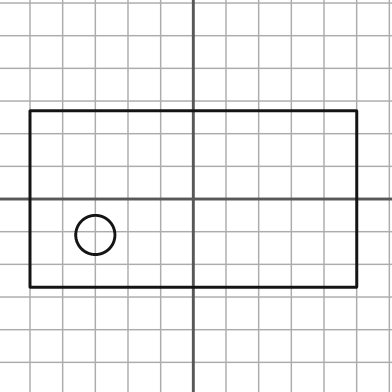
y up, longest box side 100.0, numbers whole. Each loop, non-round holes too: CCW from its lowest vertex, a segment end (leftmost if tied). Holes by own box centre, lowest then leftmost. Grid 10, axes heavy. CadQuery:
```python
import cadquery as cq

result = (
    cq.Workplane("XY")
    .moveTo(-50.0, -27.0)
    .lineTo(50.0, -27.0)
    .lineTo(50.0, 27.0)
    .lineTo(-50.0, 27.0)
    .close()
    .moveTo(-30.0, -11.0)
    .circle(6.0)
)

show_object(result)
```